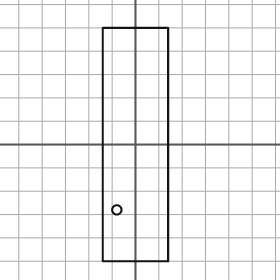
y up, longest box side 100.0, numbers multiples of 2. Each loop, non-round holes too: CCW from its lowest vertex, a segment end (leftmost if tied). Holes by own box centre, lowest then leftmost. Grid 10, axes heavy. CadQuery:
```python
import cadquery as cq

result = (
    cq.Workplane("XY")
    .moveTo(-14.0, -50.0)
    .lineTo(14.0, -50.0)
    .lineTo(14.0, 50.0)
    .lineTo(-14.0, 50.0)
    .close()
    .moveTo(-8.0, -28.0)
    .circle(2.0)
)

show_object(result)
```